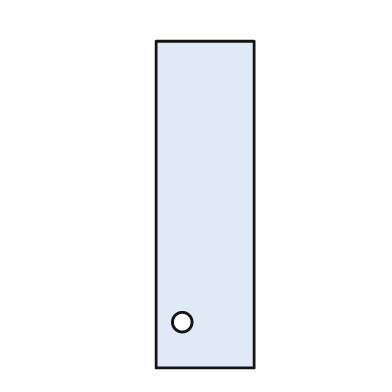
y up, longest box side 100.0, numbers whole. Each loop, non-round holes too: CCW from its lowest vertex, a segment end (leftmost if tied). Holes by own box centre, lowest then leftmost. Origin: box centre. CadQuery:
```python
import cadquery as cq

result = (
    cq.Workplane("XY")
    .moveTo(-15.0, -50.0)
    .lineTo(15.0, -50.0)
    .lineTo(15.0, 50.0)
    .lineTo(-15.0, 50.0)
    .close()
    .moveTo(-7.0, -36.0)
    .circle(3.0)
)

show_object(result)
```